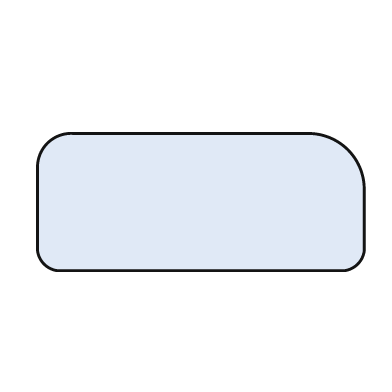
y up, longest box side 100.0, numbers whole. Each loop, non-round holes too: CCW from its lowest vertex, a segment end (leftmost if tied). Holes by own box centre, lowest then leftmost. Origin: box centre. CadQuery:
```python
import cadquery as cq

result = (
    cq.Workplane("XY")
    .moveTo(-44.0, -21.0)
    .lineTo(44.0, -21.0)
    .threePointArc((48.0, -19.0), (50.0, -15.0))
    .lineTo(50.0, 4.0)
    .threePointArc((45.0, 16.0), (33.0, 21.0))
    .lineTo(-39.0, 21.0)
    .threePointArc((-47.0, 18.0), (-50.0, 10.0))
    .lineTo(-50.0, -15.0)
    .threePointArc((-48.0, -19.0), (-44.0, -21.0))
    .close()
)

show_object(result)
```